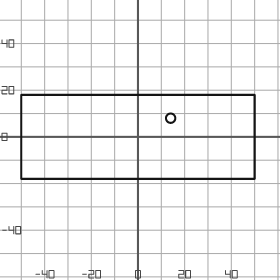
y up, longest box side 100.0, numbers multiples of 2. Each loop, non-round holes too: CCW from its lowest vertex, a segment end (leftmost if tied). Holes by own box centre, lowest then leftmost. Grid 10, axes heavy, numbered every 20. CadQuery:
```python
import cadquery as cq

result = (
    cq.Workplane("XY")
    .moveTo(-50.0, -18.0)
    .lineTo(50.0, -18.0)
    .lineTo(50.0, 18.0)
    .lineTo(-50.0, 18.0)
    .close()
    .moveTo(14.0, 8.0)
    .circle(2.0)
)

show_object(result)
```